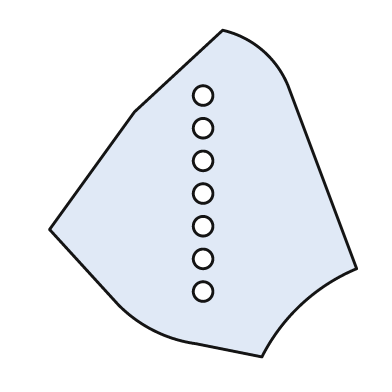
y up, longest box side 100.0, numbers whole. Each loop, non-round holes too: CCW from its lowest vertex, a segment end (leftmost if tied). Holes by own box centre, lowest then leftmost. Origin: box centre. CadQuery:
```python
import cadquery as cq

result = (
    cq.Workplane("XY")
    .moveTo(18.0, -50.0)
    .threePointArc((30.0, -34.0), (47.0, -23.0))
    .lineTo(26.0, 33.0)
    .threePointArc((18.0, 44.0), (6.0, 50.0))
    .lineTo(-21.0, 25.0)
    .lineTo(-47.0, -11.0)
    .lineTo(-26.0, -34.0)
    .threePointArc((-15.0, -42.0), (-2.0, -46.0))
    .close()
    .moveTo(0.0, -30.0)
    .circle(3.0)
    .moveTo(0.0, -20.0)
    .circle(3.0)
    .moveTo(0.0, -10.0)
    .circle(3.0)
    .moveTo(0.0, 0.0)
    .circle(3.0)
    .moveTo(0.0, 10.0)
    .circle(3.0)
    .moveTo(0.0, 20.0)
    .circle(3.0)
    .moveTo(0.0, 30.0)
    .circle(3.0)
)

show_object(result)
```